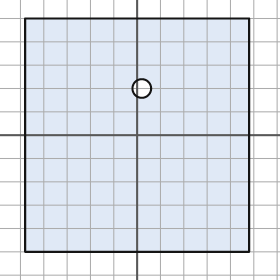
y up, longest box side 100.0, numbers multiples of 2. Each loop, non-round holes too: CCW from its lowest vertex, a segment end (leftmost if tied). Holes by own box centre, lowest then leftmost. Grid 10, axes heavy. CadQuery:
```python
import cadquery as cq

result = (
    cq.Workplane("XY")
    .moveTo(-48.0, -50.0)
    .lineTo(48.0, -50.0)
    .lineTo(48.0, 50.0)
    .lineTo(-48.0, 50.0)
    .close()
    .moveTo(2.0, 20.0)
    .circle(4.0)
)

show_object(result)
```